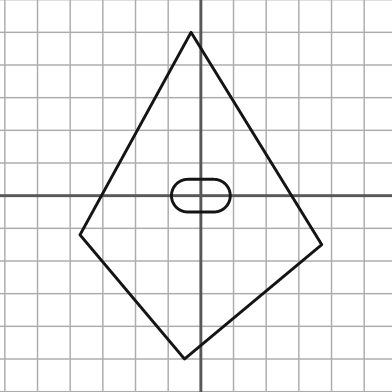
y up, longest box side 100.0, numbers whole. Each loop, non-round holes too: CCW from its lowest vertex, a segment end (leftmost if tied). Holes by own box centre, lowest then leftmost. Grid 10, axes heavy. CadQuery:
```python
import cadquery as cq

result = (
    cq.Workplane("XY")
    .moveTo(-5.0, -50.0)
    .lineTo(37.0, -15.0)
    .lineTo(-3.0, 50.0)
    .lineTo(-37.0, -12.0)
    .close()
    .moveTo(-4.0, -5.0)
    .lineTo(4.0, -5.0)
    .threePointArc((9.0, 0.0), (4.0, 5.0))
    .lineTo(-4.0, 5.0)
    .threePointArc((-9.0, 0.0), (-4.0, -5.0))
    .close()
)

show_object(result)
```